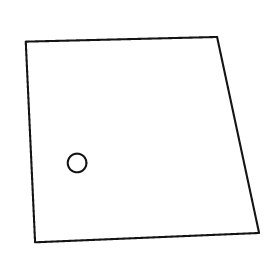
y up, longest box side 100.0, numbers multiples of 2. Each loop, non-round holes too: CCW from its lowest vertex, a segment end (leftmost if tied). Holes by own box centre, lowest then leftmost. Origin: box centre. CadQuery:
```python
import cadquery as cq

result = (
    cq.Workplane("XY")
    .moveTo(-46.0, -44.0)
    .lineTo(50.0, -40.0)
    .lineTo(32.0, 44.0)
    .lineTo(-50.0, 42.0)
    .close()
    .moveTo(-28.0, -10.0)
    .circle(4.0)
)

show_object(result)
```